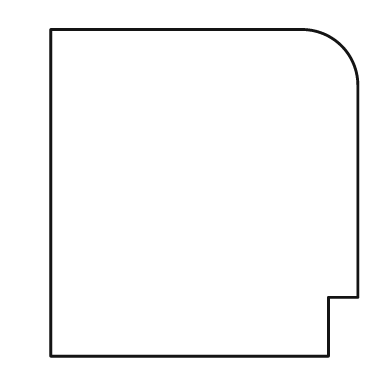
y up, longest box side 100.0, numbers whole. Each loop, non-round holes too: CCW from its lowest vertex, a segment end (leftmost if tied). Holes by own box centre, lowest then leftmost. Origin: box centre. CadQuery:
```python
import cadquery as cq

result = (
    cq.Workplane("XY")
    .moveTo(-47.0, -50.0)
    .lineTo(38.0, -50.0)
    .lineTo(38.0, -32.0)
    .lineTo(47.0, -32.0)
    .lineTo(47.0, 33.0)
    .threePointArc((42.0, 45.0), (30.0, 50.0))
    .lineTo(-47.0, 50.0)
    .close()
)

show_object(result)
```